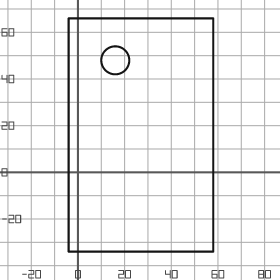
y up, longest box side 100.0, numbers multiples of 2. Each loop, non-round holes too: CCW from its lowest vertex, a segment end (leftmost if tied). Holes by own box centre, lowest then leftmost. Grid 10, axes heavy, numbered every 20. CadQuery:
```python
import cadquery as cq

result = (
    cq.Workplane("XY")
    .moveTo(-4.0, -34.0)
    .lineTo(58.0, -34.0)
    .lineTo(58.0, 66.0)
    .lineTo(-4.0, 66.0)
    .close()
    .moveTo(16.0, 48.0)
    .circle(6.0)
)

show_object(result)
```